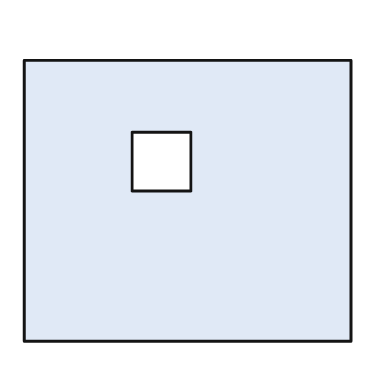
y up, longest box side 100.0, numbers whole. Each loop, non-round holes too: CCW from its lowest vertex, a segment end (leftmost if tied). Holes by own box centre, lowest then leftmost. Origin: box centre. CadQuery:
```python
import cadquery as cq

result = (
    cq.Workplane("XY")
    .moveTo(-50.0, -43.0)
    .lineTo(50.0, -43.0)
    .lineTo(50.0, 43.0)
    .lineTo(-50.0, 43.0)
    .close()
    .moveTo(-17.0, 3.0)
    .lineTo(1.0, 3.0)
    .lineTo(1.0, 21.0)
    .lineTo(-17.0, 21.0)
    .close()
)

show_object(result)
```